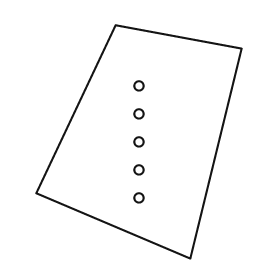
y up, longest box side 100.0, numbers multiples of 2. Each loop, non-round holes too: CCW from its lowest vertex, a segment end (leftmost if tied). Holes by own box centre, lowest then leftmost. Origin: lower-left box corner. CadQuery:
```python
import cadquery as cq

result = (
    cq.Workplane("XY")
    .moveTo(66.0, 0.0)
    .lineTo(88.0, 90.0)
    .lineTo(34.0, 100.0)
    .lineTo(0.0, 28.0)
    .close()
    .moveTo(44.0, 26.0)
    .circle(2.0)
    .moveTo(44.0, 38.0)
    .circle(2.0)
    .moveTo(44.0, 50.0)
    .circle(2.0)
    .moveTo(44.0, 62.0)
    .circle(2.0)
    .moveTo(44.0, 74.0)
    .circle(2.0)
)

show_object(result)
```